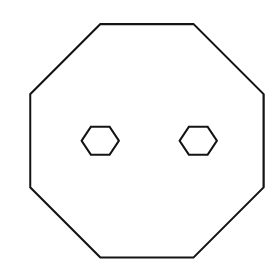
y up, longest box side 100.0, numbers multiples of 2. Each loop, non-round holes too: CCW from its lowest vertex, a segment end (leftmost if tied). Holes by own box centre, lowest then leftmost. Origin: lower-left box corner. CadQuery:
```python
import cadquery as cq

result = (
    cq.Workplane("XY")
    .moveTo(30.0, 0.0)
    .lineTo(70.0, 0.0)
    .lineTo(100.0, 30.0)
    .lineTo(100.0, 70.0)
    .lineTo(70.0, 100.0)
    .lineTo(30.0, 100.0)
    .lineTo(0.0, 70.0)
    .lineTo(0.0, 30.0)
    .close()
    .moveTo(26.0, 44.0)
    .lineTo(34.0, 44.0)
    .lineTo(38.0, 50.0)
    .lineTo(34.0, 56.0)
    .lineTo(26.0, 56.0)
    .lineTo(22.0, 50.0)
    .close()
    .moveTo(68.0, 44.0)
    .lineTo(76.0, 44.0)
    .lineTo(80.0, 50.0)
    .lineTo(76.0, 56.0)
    .lineTo(68.0, 56.0)
    .lineTo(64.0, 50.0)
    .close()
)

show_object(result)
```